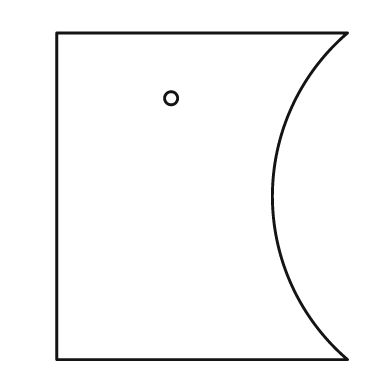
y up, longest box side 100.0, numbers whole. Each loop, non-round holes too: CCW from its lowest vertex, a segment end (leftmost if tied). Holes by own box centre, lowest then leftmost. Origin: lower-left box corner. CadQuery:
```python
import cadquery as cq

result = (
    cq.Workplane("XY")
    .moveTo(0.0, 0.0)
    .lineTo(89.0, 0.0)
    .threePointArc((66.0, 50.0), (89.0, 100.0))
    .lineTo(0.0, 100.0)
    .close()
    .moveTo(35.0, 80.0)
    .circle(2.0)
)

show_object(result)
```